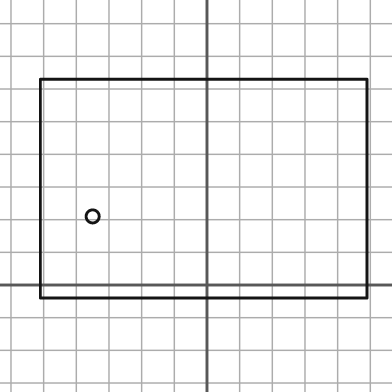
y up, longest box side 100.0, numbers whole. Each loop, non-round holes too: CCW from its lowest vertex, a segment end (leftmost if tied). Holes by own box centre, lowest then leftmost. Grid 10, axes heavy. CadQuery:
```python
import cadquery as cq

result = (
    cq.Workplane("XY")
    .moveTo(-51.0, -4.0)
    .lineTo(49.0, -4.0)
    .lineTo(49.0, 63.0)
    .lineTo(-51.0, 63.0)
    .close()
    .moveTo(-35.0, 21.0)
    .circle(2.0)
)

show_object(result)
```